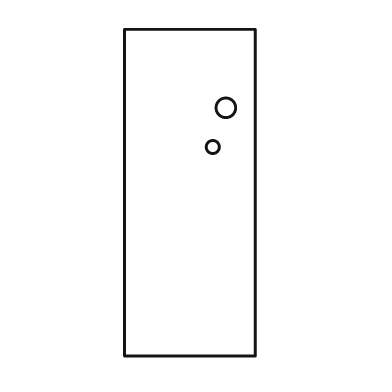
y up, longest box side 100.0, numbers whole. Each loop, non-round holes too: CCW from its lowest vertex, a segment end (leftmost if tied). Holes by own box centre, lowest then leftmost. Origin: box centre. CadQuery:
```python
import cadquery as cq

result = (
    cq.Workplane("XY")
    .moveTo(-20.0, -50.0)
    .lineTo(20.0, -50.0)
    .lineTo(20.0, 50.0)
    .lineTo(-20.0, 50.0)
    .close()
    .moveTo(7.0, 14.0)
    .circle(2.0)
    .moveTo(11.0, 26.0)
    .circle(3.0)
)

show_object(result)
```